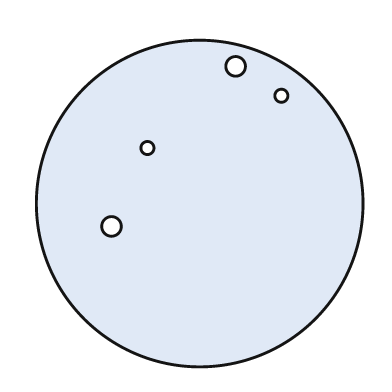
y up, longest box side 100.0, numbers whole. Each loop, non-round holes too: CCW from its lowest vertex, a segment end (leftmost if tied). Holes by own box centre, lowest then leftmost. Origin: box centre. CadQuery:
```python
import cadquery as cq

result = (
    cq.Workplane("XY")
    .moveTo(0.0, 0.0)
    .circle(50.0)
    .moveTo(-27.0, -7.0)
    .circle(3.0)
    .moveTo(-16.0, 17.0)
    .circle(2.0)
    .moveTo(25.0, 33.0)
    .circle(2.0)
    .moveTo(11.0, 42.0)
    .circle(3.0)
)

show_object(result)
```